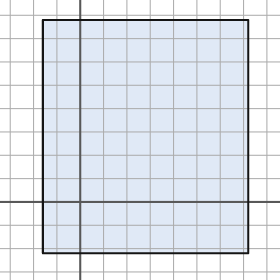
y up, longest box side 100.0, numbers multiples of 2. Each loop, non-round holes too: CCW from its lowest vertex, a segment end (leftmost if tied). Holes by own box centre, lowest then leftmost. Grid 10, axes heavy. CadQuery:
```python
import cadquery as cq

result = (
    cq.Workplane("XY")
    .moveTo(-16.0, -22.0)
    .lineTo(72.0, -22.0)
    .lineTo(72.0, 78.0)
    .lineTo(-16.0, 78.0)
    .close()
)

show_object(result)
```